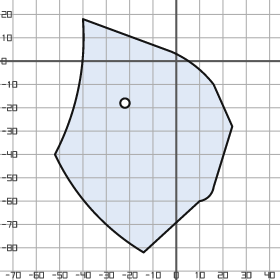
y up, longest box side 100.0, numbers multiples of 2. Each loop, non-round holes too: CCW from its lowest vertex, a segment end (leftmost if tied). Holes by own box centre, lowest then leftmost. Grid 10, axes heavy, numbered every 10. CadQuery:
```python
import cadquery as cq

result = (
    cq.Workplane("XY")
    .moveTo(-14.0, -82.0)
    .lineTo(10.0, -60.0)
    .threePointArc((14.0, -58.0), (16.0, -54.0))
    .lineTo(24.0, -28.0)
    .lineTo(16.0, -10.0)
    .threePointArc((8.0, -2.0), (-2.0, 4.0))
    .lineTo(-40.0, 18.0)
    .threePointArc((-42.0, -12.0), (-52.0, -40.0))
    .threePointArc((-36.0, -64.0), (-14.0, -82.0))
    .close()
    .moveTo(-22.0, -18.0)
    .circle(2.0)
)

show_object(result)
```